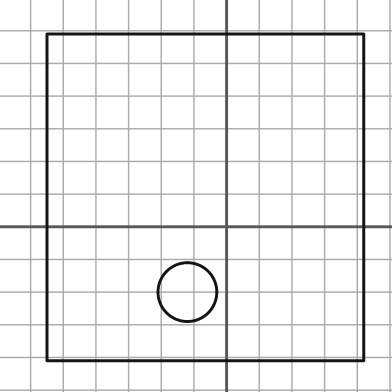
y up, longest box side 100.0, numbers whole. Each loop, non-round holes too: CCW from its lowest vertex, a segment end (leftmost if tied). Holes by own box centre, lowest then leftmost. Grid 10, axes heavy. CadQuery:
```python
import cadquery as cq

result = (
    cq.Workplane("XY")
    .moveTo(-55.0, -41.0)
    .lineTo(42.0, -41.0)
    .lineTo(42.0, 59.0)
    .lineTo(-55.0, 59.0)
    .close()
    .moveTo(-12.0, -20.0)
    .circle(9.0)
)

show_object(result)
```